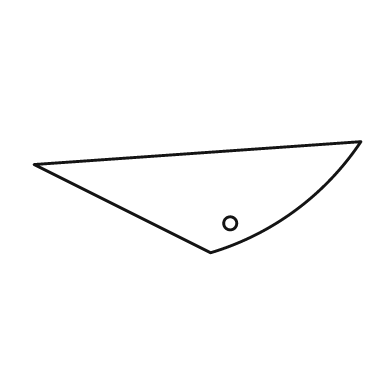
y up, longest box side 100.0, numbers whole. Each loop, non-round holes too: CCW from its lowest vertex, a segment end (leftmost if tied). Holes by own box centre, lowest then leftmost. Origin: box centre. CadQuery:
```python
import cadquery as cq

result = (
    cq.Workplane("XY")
    .moveTo(4.0, -17.0)
    .threePointArc((30.0, -4.0), (50.0, 17.0))
    .lineTo(-50.0, 10.0)
    .close()
    .moveTo(10.0, -8.0)
    .circle(2.0)
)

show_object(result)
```